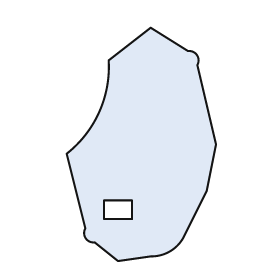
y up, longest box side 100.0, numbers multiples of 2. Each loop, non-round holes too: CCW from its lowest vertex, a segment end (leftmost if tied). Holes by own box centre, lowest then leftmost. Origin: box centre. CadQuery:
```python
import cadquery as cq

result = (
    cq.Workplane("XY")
    .moveTo(-10.0, -50.0)
    .lineTo(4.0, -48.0)
    .threePointArc((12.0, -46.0), (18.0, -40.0))
    .lineTo(28.0, -20.0)
    .lineTo(32.0, 0.0)
    .lineTo(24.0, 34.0)
    .threePointArc((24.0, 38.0), (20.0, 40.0))
    .lineTo(4.0, 50.0)
    .lineTo(-14.0, 36.0)
    .threePointArc((-18.0, 14.0), (-32.0, -4.0))
    .lineTo(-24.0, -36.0)
    .threePointArc((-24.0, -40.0), (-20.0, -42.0))
    .close()
    .moveTo(-16.0, -32.0)
    .lineTo(-4.0, -32.0)
    .lineTo(-4.0, -24.0)
    .lineTo(-16.0, -24.0)
    .close()
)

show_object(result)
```